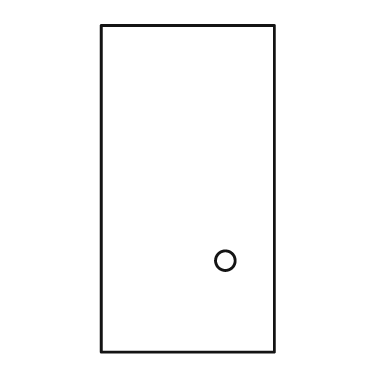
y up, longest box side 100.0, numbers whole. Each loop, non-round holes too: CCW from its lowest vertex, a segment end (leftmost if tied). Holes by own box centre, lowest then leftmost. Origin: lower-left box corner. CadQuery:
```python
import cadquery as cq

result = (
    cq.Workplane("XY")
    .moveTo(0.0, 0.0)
    .lineTo(53.0, 0.0)
    .lineTo(53.0, 100.0)
    .lineTo(0.0, 100.0)
    .close()
    .moveTo(38.0, 28.0)
    .circle(3.0)
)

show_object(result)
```